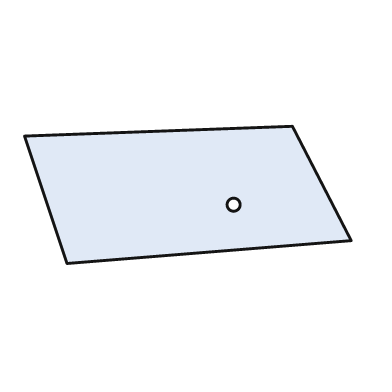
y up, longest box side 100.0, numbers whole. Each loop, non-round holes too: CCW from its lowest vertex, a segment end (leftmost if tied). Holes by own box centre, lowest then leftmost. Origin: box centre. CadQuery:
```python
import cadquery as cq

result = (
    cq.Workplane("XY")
    .moveTo(-37.0, -21.0)
    .lineTo(50.0, -14.0)
    .lineTo(32.0, 21.0)
    .lineTo(-50.0, 18.0)
    .close()
    .moveTo(14.0, -3.0)
    .circle(2.0)
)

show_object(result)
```